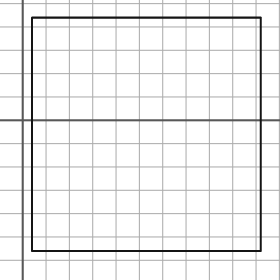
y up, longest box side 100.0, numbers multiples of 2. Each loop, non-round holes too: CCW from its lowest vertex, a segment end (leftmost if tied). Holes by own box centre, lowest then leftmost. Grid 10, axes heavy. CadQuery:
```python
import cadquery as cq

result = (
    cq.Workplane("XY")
    .moveTo(4.0, -56.0)
    .lineTo(102.0, -56.0)
    .lineTo(102.0, 44.0)
    .lineTo(4.0, 44.0)
    .close()
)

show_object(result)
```